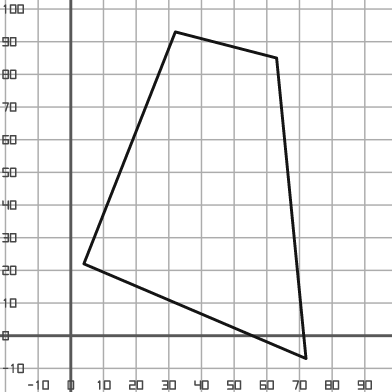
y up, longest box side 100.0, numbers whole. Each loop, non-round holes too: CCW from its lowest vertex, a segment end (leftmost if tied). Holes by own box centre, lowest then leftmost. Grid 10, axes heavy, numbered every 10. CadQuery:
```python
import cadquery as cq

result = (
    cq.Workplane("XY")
    .moveTo(72.0, -7.0)
    .lineTo(63.0, 85.0)
    .lineTo(32.0, 93.0)
    .lineTo(4.0, 22.0)
    .close()
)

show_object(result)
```